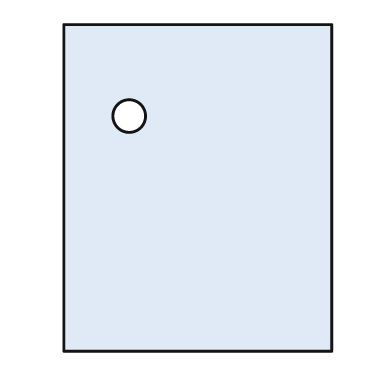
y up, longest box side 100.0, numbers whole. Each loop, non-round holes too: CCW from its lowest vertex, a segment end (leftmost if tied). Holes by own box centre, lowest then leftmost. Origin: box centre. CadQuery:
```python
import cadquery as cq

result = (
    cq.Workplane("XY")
    .moveTo(-41.0, -50.0)
    .lineTo(41.0, -50.0)
    .lineTo(41.0, 50.0)
    .lineTo(-41.0, 50.0)
    .close()
    .moveTo(-21.0, 22.0)
    .circle(5.0)
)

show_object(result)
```